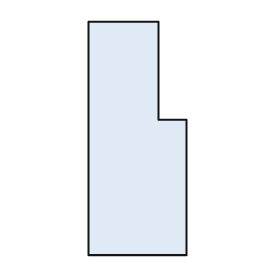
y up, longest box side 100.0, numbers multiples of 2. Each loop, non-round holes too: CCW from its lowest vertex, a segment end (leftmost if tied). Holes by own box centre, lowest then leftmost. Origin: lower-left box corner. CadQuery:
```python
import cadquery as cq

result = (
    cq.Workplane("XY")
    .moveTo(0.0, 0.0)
    .lineTo(42.0, 0.0)
    .lineTo(42.0, 58.0)
    .lineTo(30.0, 58.0)
    .lineTo(30.0, 100.0)
    .lineTo(0.0, 100.0)
    .close()
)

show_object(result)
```